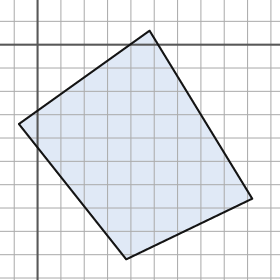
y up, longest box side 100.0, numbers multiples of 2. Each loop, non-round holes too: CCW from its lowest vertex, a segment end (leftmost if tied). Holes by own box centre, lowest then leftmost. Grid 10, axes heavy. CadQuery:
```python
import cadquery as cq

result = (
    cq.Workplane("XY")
    .moveTo(38.0, -92.0)
    .lineTo(92.0, -66.0)
    .lineTo(48.0, 6.0)
    .lineTo(-8.0, -34.0)
    .close()
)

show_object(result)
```